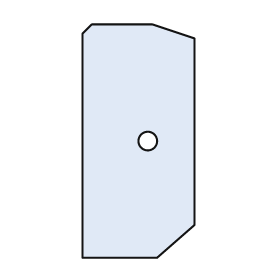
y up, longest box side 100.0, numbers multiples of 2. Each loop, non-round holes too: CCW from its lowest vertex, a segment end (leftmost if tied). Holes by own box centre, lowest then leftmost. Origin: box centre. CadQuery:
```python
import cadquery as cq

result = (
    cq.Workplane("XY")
    .moveTo(-24.0, -50.0)
    .lineTo(8.0, -50.0)
    .lineTo(24.0, -36.0)
    .lineTo(24.0, 44.0)
    .lineTo(6.0, 50.0)
    .lineTo(-20.0, 50.0)
    .lineTo(-24.0, 46.0)
    .close()
    .moveTo(4.0, 0.0)
    .circle(4.0)
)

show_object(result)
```